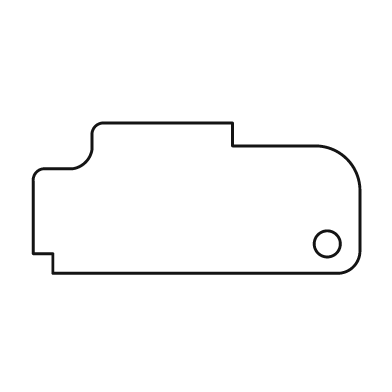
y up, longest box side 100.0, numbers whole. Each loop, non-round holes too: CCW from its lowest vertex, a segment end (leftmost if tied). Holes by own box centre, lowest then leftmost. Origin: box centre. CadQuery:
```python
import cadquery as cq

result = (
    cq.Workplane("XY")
    .moveTo(-44.0, -23.0)
    .lineTo(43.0, -23.0)
    .threePointArc((48.0, -21.0), (50.0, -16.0))
    .lineTo(50.0, 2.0)
    .threePointArc((46.0, 12.0), (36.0, 16.0))
    .lineTo(11.0, 16.0)
    .lineTo(11.0, 23.0)
    .lineTo(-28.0, 23.0)
    .threePointArc((-31.0, 22.0), (-32.0, 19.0))
    .lineTo(-32.0, 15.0)
    .threePointArc((-34.0, 11.0), (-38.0, 9.0))
    .lineTo(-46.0, 9.0)
    .threePointArc((-49.0, 8.0), (-50.0, 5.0))
    .lineTo(-50.0, -17.0)
    .lineTo(-44.0, -17.0)
    .close()
    .moveTo(40.0, -14.0)
    .circle(4.0)
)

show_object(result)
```